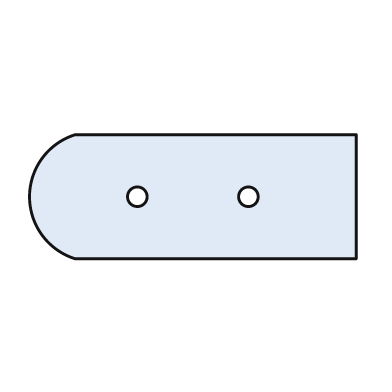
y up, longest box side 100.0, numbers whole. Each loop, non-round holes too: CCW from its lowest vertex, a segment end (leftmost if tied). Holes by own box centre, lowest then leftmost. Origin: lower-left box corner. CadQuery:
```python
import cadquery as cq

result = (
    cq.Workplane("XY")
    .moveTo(14.0, 0.0)
    .lineTo(100.0, 0.0)
    .lineTo(100.0, 38.0)
    .lineTo(14.0, 38.0)
    .threePointArc((0.0, 19.0), (14.0, 0.0))
    .close()
    .moveTo(33.0, 19.0)
    .circle(3.0)
    .moveTo(67.0, 19.0)
    .circle(3.0)
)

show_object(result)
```